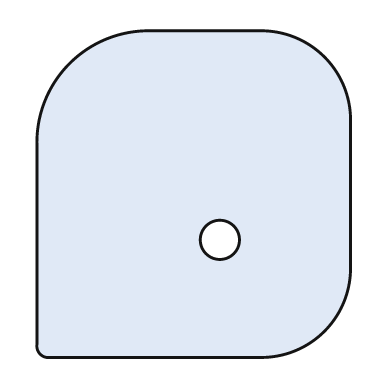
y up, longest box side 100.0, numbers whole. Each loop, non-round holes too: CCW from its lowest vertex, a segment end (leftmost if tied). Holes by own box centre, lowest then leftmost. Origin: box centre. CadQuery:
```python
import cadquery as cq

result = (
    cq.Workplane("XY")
    .moveTo(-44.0, -50.0)
    .lineTo(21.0, -50.0)
    .threePointArc((40.0, -42.0), (48.0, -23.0))
    .lineTo(48.0, 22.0)
    .threePointArc((40.0, 42.0), (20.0, 50.0))
    .lineTo(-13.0, 50.0)
    .threePointArc((-38.0, 40.0), (-48.0, 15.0))
    .lineTo(-48.0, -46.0)
    .threePointArc((-47.0, -49.0), (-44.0, -50.0))
    .close()
    .moveTo(8.0, -14.0)
    .circle(6.0)
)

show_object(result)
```